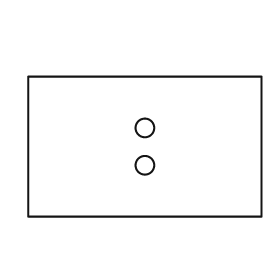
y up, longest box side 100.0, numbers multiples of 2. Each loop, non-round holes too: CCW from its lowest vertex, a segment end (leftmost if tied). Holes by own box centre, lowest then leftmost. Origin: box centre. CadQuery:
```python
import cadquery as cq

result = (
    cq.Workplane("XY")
    .moveTo(-50.0, -30.0)
    .lineTo(50.0, -30.0)
    .lineTo(50.0, 30.0)
    .lineTo(-50.0, 30.0)
    .close()
    .moveTo(0.0, -8.0)
    .circle(4.0)
    .moveTo(0.0, 8.0)
    .circle(4.0)
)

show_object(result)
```